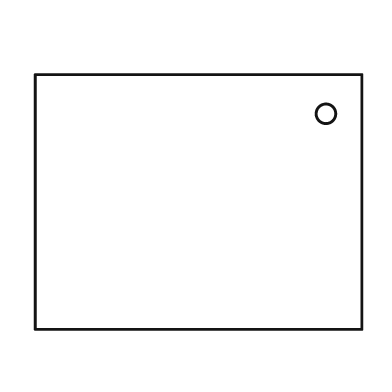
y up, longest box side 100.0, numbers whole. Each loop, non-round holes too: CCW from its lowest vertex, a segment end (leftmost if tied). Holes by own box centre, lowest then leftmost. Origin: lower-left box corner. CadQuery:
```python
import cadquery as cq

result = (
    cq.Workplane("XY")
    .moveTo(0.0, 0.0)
    .lineTo(100.0, 0.0)
    .lineTo(100.0, 78.0)
    .lineTo(0.0, 78.0)
    .close()
    .moveTo(89.0, 66.0)
    .circle(3.0)
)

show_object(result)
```